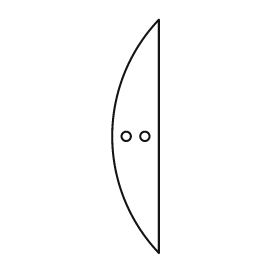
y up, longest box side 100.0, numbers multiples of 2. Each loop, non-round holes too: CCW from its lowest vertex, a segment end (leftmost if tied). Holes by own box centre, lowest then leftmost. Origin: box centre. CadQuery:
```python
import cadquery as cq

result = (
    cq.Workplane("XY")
    .moveTo(10.0, -50.0)
    .lineTo(10.0, 50.0)
    .threePointArc((-10.0, 0.0), (10.0, -50.0))
    .close()
    .moveTo(-4.0, 0.0)
    .circle(2.0)
    .moveTo(4.0, 0.0)
    .circle(2.0)
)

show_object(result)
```